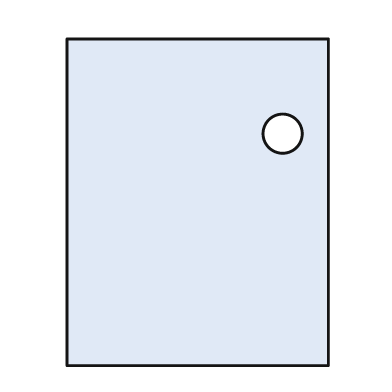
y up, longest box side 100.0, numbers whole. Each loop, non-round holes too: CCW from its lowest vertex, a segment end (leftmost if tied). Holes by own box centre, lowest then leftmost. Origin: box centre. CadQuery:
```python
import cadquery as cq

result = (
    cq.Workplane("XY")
    .moveTo(-40.0, -50.0)
    .lineTo(40.0, -50.0)
    .lineTo(40.0, 50.0)
    .lineTo(-40.0, 50.0)
    .close()
    .moveTo(26.0, 21.0)
    .circle(6.0)
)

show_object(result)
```